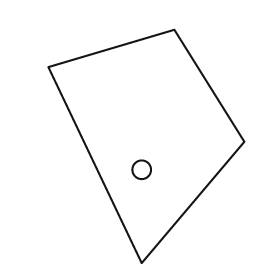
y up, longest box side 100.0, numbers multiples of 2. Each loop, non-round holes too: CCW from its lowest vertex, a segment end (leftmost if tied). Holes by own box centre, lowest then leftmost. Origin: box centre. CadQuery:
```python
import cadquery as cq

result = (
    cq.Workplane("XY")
    .moveTo(-2.0, -50.0)
    .lineTo(42.0, 2.0)
    .lineTo(12.0, 50.0)
    .lineTo(-42.0, 34.0)
    .close()
    .moveTo(-2.0, -10.0)
    .circle(4.0)
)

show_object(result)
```